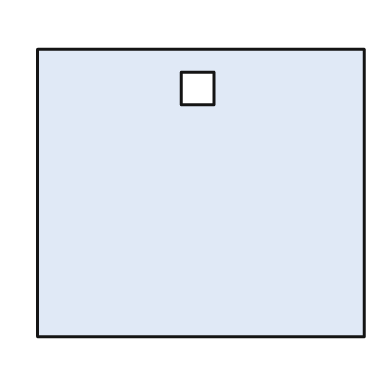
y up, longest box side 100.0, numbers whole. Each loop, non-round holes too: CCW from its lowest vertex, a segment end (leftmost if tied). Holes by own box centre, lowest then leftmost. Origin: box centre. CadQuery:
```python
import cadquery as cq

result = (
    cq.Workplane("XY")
    .moveTo(-50.0, -44.0)
    .lineTo(50.0, -44.0)
    .lineTo(50.0, 44.0)
    .lineTo(-50.0, 44.0)
    .close()
    .moveTo(-6.0, 27.0)
    .lineTo(4.0, 27.0)
    .lineTo(4.0, 37.0)
    .lineTo(-6.0, 37.0)
    .close()
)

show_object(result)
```